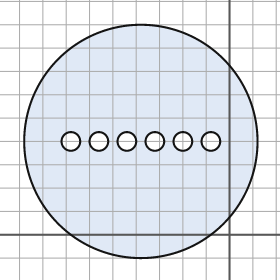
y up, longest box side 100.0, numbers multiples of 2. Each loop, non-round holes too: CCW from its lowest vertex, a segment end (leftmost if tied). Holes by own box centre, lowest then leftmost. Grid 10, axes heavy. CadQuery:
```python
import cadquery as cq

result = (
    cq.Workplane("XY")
    .moveTo(-38.0, 40.0)
    .circle(50.0)
    .moveTo(-68.0, 40.0)
    .circle(4.0)
    .moveTo(-56.0, 40.0)
    .circle(4.0)
    .moveTo(-44.0, 40.0)
    .circle(4.0)
    .moveTo(-32.0, 40.0)
    .circle(4.0)
    .moveTo(-20.0, 40.0)
    .circle(4.0)
    .moveTo(-8.0, 40.0)
    .circle(4.0)
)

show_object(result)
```